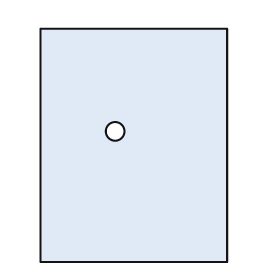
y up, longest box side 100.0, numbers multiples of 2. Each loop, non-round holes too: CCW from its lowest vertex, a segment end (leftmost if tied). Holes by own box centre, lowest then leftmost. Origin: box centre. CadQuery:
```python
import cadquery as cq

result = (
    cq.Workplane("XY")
    .moveTo(-40.0, -50.0)
    .lineTo(40.0, -50.0)
    .lineTo(40.0, 50.0)
    .lineTo(-40.0, 50.0)
    .close()
    .moveTo(-8.0, 6.0)
    .circle(4.0)
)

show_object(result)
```